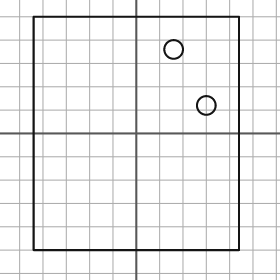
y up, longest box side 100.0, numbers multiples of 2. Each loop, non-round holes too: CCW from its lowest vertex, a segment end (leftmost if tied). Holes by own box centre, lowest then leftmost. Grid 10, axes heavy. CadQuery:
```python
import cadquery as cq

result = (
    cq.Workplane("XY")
    .moveTo(-44.0, -50.0)
    .lineTo(44.0, -50.0)
    .lineTo(44.0, 50.0)
    .lineTo(-44.0, 50.0)
    .close()
    .moveTo(30.0, 12.0)
    .circle(4.0)
    .moveTo(16.0, 36.0)
    .circle(4.0)
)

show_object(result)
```